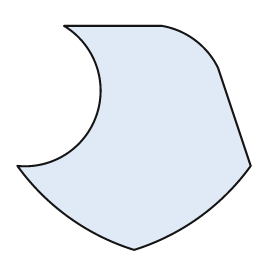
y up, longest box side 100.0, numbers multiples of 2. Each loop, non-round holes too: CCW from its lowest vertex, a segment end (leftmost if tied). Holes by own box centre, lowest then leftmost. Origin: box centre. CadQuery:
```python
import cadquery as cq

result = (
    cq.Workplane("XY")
    .moveTo(0.0, -48.0)
    .threePointArc((28.0, -34.0), (50.0, -12.0))
    .lineTo(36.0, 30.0)
    .threePointArc((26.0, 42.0), (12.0, 48.0))
    .lineTo(-30.0, 48.0)
    .threePointArc((-16.0, 10.0), (-50.0, -12.0))
    .threePointArc((-28.0, -34.0), (0.0, -48.0))
    .close()
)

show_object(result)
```